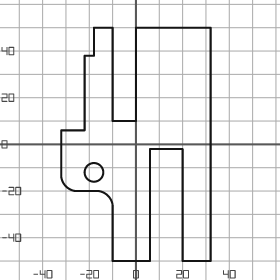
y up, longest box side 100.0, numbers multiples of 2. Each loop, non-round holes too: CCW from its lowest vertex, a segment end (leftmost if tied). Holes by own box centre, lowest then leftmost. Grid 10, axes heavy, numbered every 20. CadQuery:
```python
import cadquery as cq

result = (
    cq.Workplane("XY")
    .moveTo(-10.0, -50.0)
    .lineTo(6.0, -50.0)
    .lineTo(6.0, -2.0)
    .lineTo(20.0, -2.0)
    .lineTo(20.0, -50.0)
    .lineTo(32.0, -50.0)
    .lineTo(32.0, 50.0)
    .lineTo(0.0, 50.0)
    .lineTo(0.0, 10.0)
    .lineTo(-10.0, 10.0)
    .lineTo(-10.0, 50.0)
    .lineTo(-18.0, 50.0)
    .lineTo(-18.0, 38.0)
    .lineTo(-22.0, 38.0)
    .lineTo(-22.0, 6.0)
    .lineTo(-32.0, 6.0)
    .lineTo(-32.0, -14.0)
    .threePointArc((-30.0, -18.0), (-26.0, -20.0))
    .lineTo(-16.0, -20.0)
    .threePointArc((-12.0, -22.0), (-10.0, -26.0))
    .close()
    .moveTo(-18.0, -12.0)
    .circle(4.0)
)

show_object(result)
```